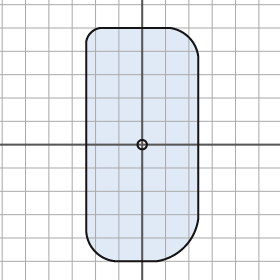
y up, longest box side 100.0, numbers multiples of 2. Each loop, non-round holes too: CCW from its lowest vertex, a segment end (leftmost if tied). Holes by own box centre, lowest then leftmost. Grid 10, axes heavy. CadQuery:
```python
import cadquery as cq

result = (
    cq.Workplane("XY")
    .moveTo(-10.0, -50.0)
    .lineTo(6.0, -50.0)
    .threePointArc((18.0, -44.0), (24.0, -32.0))
    .lineTo(24.0, 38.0)
    .threePointArc((20.0, 46.0), (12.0, 50.0))
    .lineTo(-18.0, 50.0)
    .threePointArc((-22.0, 48.0), (-24.0, 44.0))
    .lineTo(-24.0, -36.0)
    .threePointArc((-20.0, -46.0), (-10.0, -50.0))
    .close()
    .moveTo(0.0, 0.0)
    .circle(2.0)
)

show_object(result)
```